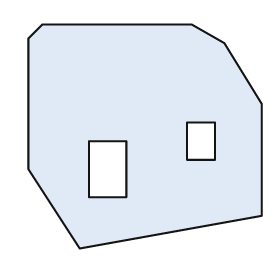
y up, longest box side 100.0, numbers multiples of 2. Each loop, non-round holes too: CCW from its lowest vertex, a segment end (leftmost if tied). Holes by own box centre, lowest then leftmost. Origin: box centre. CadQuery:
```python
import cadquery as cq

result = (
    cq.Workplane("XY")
    .moveTo(-28.0, -48.0)
    .lineTo(50.0, -34.0)
    .lineTo(50.0, 14.0)
    .lineTo(34.0, 40.0)
    .lineTo(20.0, 48.0)
    .lineTo(-44.0, 48.0)
    .lineTo(-50.0, 42.0)
    .lineTo(-50.0, -14.0)
    .close()
    .moveTo(-24.0, -26.0)
    .lineTo(-8.0, -26.0)
    .lineTo(-8.0, -2.0)
    .lineTo(-24.0, -2.0)
    .close()
    .moveTo(18.0, -10.0)
    .lineTo(30.0, -10.0)
    .lineTo(30.0, 6.0)
    .lineTo(18.0, 6.0)
    .close()
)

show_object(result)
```